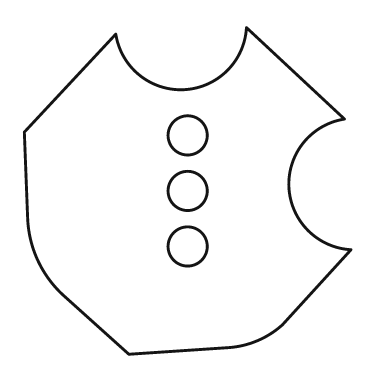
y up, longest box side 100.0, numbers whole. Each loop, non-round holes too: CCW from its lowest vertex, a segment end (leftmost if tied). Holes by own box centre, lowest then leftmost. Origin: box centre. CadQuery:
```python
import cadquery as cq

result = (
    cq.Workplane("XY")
    .moveTo(-18.0, -50.0)
    .lineTo(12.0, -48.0)
    .threePointArc((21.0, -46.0), (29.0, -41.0))
    .lineTo(50.0, -18.0)
    .threePointArc((31.0, 1.0), (48.0, 22.0))
    .lineTo(18.0, 50.0)
    .threePointArc((-1.0, 31.0), (-22.0, 48.0))
    .lineTo(-50.0, 18.0)
    .lineTo(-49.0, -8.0)
    .threePointArc((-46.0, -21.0), (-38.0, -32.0))
    .close()
    .moveTo(0.0, -17.0)
    .circle(6.0)
    .moveTo(0.0, 0.0)
    .circle(6.0)
    .moveTo(0.0, 17.0)
    .circle(6.0)
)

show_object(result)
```